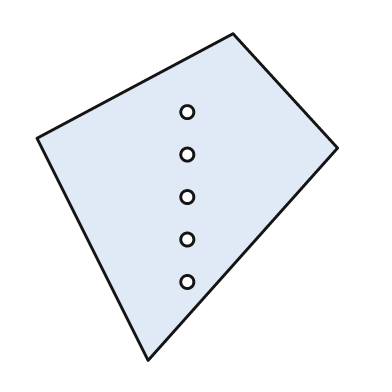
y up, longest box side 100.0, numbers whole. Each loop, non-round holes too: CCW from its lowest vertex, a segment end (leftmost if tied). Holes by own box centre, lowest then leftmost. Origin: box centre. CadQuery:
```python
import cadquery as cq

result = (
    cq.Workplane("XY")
    .moveTo(-12.0, -50.0)
    .lineTo(46.0, 15.0)
    .lineTo(14.0, 50.0)
    .lineTo(-46.0, 18.0)
    .close()
    .moveTo(0.0, -26.0)
    .circle(2.0)
    .moveTo(0.0, -13.0)
    .circle(2.0)
    .moveTo(0.0, 0.0)
    .circle(2.0)
    .moveTo(0.0, 13.0)
    .circle(2.0)
    .moveTo(0.0, 26.0)
    .circle(2.0)
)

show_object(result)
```